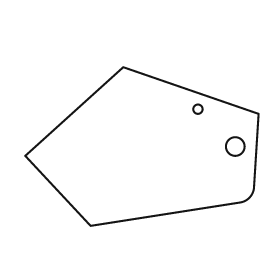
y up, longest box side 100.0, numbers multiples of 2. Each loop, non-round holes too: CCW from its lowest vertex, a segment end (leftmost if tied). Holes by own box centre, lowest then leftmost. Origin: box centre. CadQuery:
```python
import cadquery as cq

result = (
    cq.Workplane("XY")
    .moveTo(-22.0, -34.0)
    .lineTo(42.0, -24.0)
    .threePointArc((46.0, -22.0), (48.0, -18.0))
    .lineTo(50.0, 14.0)
    .lineTo(-8.0, 34.0)
    .lineTo(-50.0, -4.0)
    .close()
    .moveTo(40.0, 0.0)
    .circle(4.0)
    .moveTo(24.0, 16.0)
    .circle(2.0)
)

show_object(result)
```